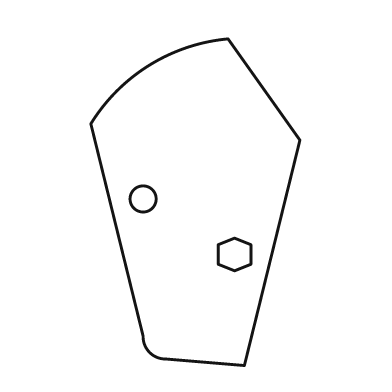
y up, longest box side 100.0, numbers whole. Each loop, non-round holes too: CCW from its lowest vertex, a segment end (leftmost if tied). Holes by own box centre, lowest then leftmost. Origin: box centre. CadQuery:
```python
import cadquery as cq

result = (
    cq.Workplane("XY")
    .moveTo(15.0, -50.0)
    .lineTo(32.0, 19.0)
    .lineTo(10.0, 50.0)
    .threePointArc((-14.0, 42.0), (-32.0, 24.0))
    .lineTo(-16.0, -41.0)
    .threePointArc((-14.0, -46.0), (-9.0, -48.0))
    .close()
    .moveTo(12.0, -21.0)
    .lineTo(17.0, -19.0)
    .lineTo(17.0, -13.0)
    .lineTo(12.0, -11.0)
    .lineTo(7.0, -13.0)
    .lineTo(7.0, -19.0)
    .close()
    .moveTo(-16.0, 1.0)
    .circle(4.0)
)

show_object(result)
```